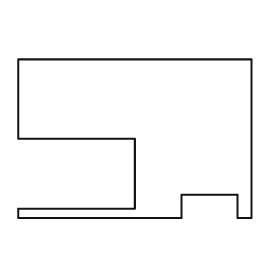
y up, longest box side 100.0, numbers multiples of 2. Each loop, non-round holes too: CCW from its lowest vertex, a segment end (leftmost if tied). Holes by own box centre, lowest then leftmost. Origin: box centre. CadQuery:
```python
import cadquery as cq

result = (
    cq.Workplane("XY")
    .moveTo(-50.0, -34.0)
    .lineTo(20.0, -34.0)
    .lineTo(20.0, -24.0)
    .lineTo(44.0, -24.0)
    .lineTo(44.0, -34.0)
    .lineTo(50.0, -34.0)
    .lineTo(50.0, 34.0)
    .lineTo(-50.0, 34.0)
    .lineTo(-50.0, 0.0)
    .lineTo(0.0, 0.0)
    .lineTo(0.0, -30.0)
    .lineTo(-50.0, -30.0)
    .close()
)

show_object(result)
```